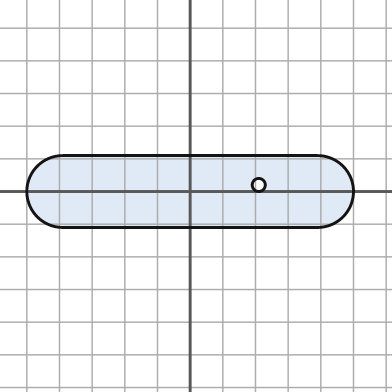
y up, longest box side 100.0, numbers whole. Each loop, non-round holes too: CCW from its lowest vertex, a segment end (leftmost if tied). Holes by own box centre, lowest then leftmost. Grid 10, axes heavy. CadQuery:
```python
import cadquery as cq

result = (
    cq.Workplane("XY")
    .moveTo(-39.0, -11.0)
    .lineTo(39.0, -11.0)
    .threePointArc((50.0, 0.0), (39.0, 11.0))
    .lineTo(-39.0, 11.0)
    .threePointArc((-50.0, 0.0), (-39.0, -11.0))
    .close()
    .moveTo(21.0, 2.0)
    .circle(2.0)
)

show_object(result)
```